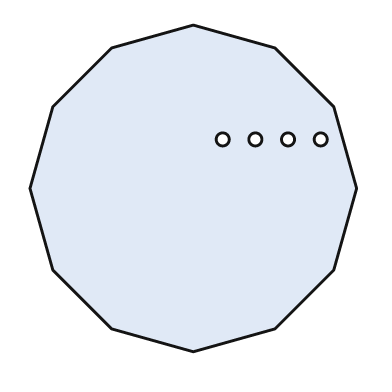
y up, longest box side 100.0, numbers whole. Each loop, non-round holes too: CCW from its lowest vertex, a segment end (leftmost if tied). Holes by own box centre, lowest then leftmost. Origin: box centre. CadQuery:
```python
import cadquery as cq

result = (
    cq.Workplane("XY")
    .moveTo(0.0, -50.0)
    .lineTo(25.0, -43.0)
    .lineTo(43.0, -25.0)
    .lineTo(50.0, 0.0)
    .lineTo(43.0, 25.0)
    .lineTo(25.0, 43.0)
    .lineTo(0.0, 50.0)
    .lineTo(-25.0, 43.0)
    .lineTo(-43.0, 25.0)
    .lineTo(-50.0, 0.0)
    .lineTo(-43.0, -25.0)
    .lineTo(-25.0, -43.0)
    .close()
    .moveTo(9.0, 15.0)
    .circle(2.0)
    .moveTo(19.0, 15.0)
    .circle(2.0)
    .moveTo(29.0, 15.0)
    .circle(2.0)
    .moveTo(39.0, 15.0)
    .circle(2.0)
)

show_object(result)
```